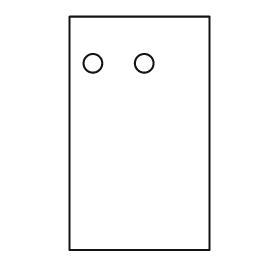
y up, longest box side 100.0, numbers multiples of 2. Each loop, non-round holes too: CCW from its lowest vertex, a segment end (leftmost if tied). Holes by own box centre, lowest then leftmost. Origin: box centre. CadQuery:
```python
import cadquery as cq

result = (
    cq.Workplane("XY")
    .moveTo(-30.0, -50.0)
    .lineTo(30.0, -50.0)
    .lineTo(30.0, 50.0)
    .lineTo(-30.0, 50.0)
    .close()
    .moveTo(-20.0, 30.0)
    .circle(4.0)
    .moveTo(2.0, 30.0)
    .circle(4.0)
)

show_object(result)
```